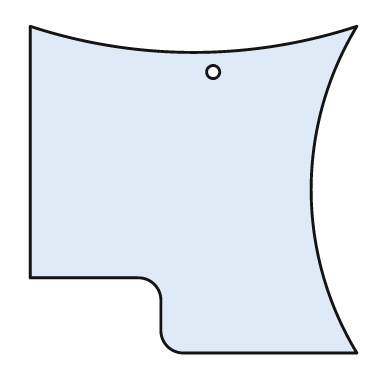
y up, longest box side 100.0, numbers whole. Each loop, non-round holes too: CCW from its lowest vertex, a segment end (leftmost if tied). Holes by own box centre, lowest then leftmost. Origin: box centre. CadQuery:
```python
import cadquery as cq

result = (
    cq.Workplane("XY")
    .moveTo(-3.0, -50.0)
    .lineTo(50.0, -50.0)
    .threePointArc((36.0, 0.0), (50.0, 50.0))
    .threePointArc((0.0, 42.0), (-50.0, 50.0))
    .lineTo(-50.0, -27.0)
    .lineTo(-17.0, -27.0)
    .threePointArc((-12.0, -29.0), (-10.0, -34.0))
    .lineTo(-10.0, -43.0)
    .threePointArc((-8.0, -48.0), (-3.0, -50.0))
    .close()
    .moveTo(6.0, 36.0)
    .circle(2.0)
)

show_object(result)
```